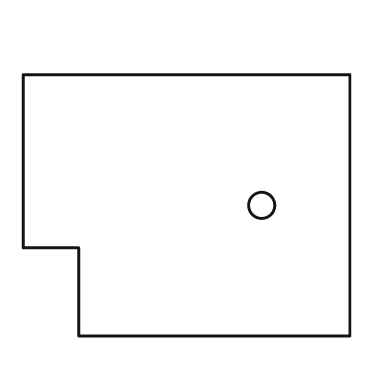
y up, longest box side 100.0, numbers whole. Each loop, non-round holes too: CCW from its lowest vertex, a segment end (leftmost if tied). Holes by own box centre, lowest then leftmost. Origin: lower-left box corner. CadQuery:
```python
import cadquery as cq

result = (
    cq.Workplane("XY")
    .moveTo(17.0, 0.0)
    .lineTo(100.0, 0.0)
    .lineTo(100.0, 80.0)
    .lineTo(0.0, 80.0)
    .lineTo(0.0, 27.0)
    .lineTo(17.0, 27.0)
    .close()
    .moveTo(73.0, 40.0)
    .circle(4.0)
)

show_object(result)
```